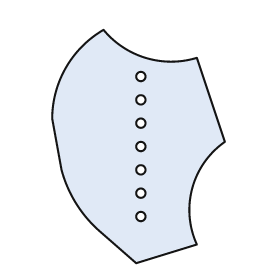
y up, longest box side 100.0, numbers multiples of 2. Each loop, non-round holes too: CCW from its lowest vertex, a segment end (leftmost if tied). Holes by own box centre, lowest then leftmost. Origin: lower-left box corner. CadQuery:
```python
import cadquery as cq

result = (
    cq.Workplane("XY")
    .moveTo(36.0, 0.0)
    .lineTo(62.0, 8.0)
    .threePointArc((60.0, 32.0), (74.0, 52.0))
    .lineTo(62.0, 88.0)
    .threePointArc((40.0, 88.0), (22.0, 100.0))
    .threePointArc((6.0, 84.0), (0.0, 62.0))
    .lineTo(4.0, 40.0)
    .threePointArc((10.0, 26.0), (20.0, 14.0))
    .close()
    .moveTo(38.0, 20.0)
    .circle(2.0)
    .moveTo(38.0, 30.0)
    .circle(2.0)
    .moveTo(38.0, 40.0)
    .circle(2.0)
    .moveTo(38.0, 50.0)
    .circle(2.0)
    .moveTo(38.0, 60.0)
    .circle(2.0)
    .moveTo(38.0, 70.0)
    .circle(2.0)
    .moveTo(38.0, 80.0)
    .circle(2.0)
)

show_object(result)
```